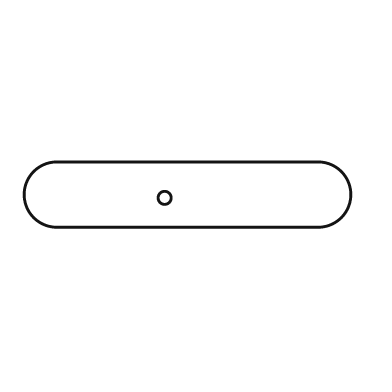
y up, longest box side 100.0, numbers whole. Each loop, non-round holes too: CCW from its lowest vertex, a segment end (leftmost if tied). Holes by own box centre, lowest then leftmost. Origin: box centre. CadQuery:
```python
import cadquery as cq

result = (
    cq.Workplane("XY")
    .moveTo(-40.0, -10.0)
    .lineTo(40.0, -10.0)
    .threePointArc((50.0, 0.0), (40.0, 10.0))
    .lineTo(-40.0, 10.0)
    .threePointArc((-50.0, 0.0), (-40.0, -10.0))
    .close()
    .moveTo(-7.0, -1.0)
    .circle(2.0)
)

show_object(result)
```